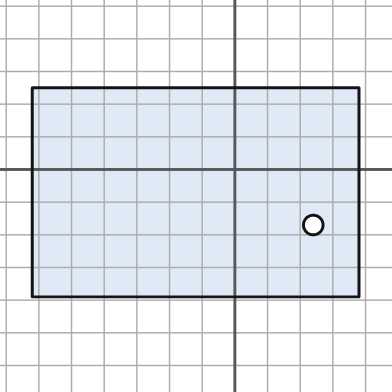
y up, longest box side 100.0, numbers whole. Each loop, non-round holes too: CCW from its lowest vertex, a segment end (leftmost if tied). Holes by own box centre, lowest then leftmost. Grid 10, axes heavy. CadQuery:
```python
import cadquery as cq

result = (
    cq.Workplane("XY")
    .moveTo(-62.0, -39.0)
    .lineTo(38.0, -39.0)
    .lineTo(38.0, 25.0)
    .lineTo(-62.0, 25.0)
    .close()
    .moveTo(24.0, -17.0)
    .circle(3.0)
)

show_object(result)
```